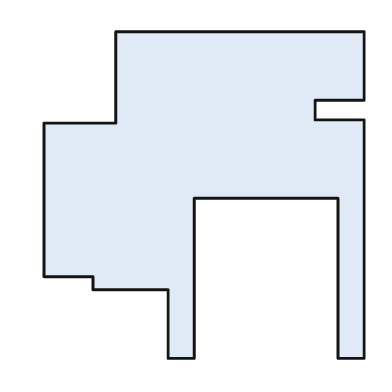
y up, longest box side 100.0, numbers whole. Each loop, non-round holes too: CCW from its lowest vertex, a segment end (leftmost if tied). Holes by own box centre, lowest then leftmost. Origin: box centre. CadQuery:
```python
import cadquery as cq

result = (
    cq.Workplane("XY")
    .moveTo(-11.0, -50.0)
    .lineTo(-3.0, -50.0)
    .lineTo(-3.0, -1.0)
    .lineTo(41.0, -1.0)
    .lineTo(41.0, -50.0)
    .lineTo(49.0, -50.0)
    .lineTo(49.0, 23.0)
    .lineTo(34.0, 23.0)
    .lineTo(34.0, 29.0)
    .lineTo(49.0, 29.0)
    .lineTo(49.0, 50.0)
    .lineTo(-27.0, 50.0)
    .lineTo(-27.0, 22.0)
    .lineTo(-49.0, 22.0)
    .lineTo(-49.0, -25.0)
    .lineTo(-34.0, -25.0)
    .lineTo(-34.0, -29.0)
    .lineTo(-11.0, -29.0)
    .close()
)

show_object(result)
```